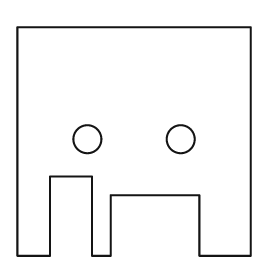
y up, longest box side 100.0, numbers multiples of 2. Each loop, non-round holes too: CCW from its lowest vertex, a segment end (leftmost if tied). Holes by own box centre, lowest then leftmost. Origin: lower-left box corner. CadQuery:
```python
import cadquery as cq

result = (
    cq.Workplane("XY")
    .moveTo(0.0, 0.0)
    .lineTo(14.0, 0.0)
    .lineTo(14.0, 34.0)
    .lineTo(32.0, 34.0)
    .lineTo(32.0, 0.0)
    .lineTo(40.0, 0.0)
    .lineTo(40.0, 26.0)
    .lineTo(78.0, 26.0)
    .lineTo(78.0, 0.0)
    .lineTo(100.0, 0.0)
    .lineTo(100.0, 98.0)
    .lineTo(0.0, 98.0)
    .close()
    .moveTo(30.0, 50.0)
    .circle(6.0)
    .moveTo(70.0, 50.0)
    .circle(6.0)
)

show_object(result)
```